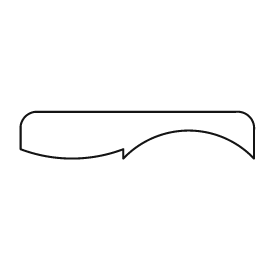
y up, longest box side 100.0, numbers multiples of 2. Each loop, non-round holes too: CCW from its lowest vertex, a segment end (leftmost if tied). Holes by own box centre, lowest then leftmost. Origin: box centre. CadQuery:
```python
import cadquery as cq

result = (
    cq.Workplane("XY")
    .moveTo(-6.0, -10.0)
    .threePointArc((22.0, 2.0), (50.0, -10.0))
    .lineTo(50.0, 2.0)
    .threePointArc((48.0, 8.0), (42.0, 10.0))
    .lineTo(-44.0, 10.0)
    .threePointArc((-48.0, 8.0), (-50.0, 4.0))
    .lineTo(-50.0, -6.0)
    .threePointArc((-28.0, -10.0), (-6.0, -6.0))
    .close()
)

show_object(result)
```